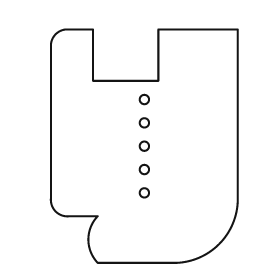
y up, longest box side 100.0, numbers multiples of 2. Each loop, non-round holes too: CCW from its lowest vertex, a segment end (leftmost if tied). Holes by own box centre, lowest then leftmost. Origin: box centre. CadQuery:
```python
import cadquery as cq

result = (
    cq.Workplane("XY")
    .moveTo(-20.0, -50.0)
    .lineTo(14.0, -50.0)
    .threePointArc((32.0, -42.0), (40.0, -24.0))
    .lineTo(40.0, 50.0)
    .lineTo(6.0, 50.0)
    .lineTo(6.0, 28.0)
    .lineTo(-22.0, 28.0)
    .lineTo(-22.0, 50.0)
    .lineTo(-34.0, 50.0)
    .threePointArc((-38.0, 48.0), (-40.0, 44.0))
    .lineTo(-40.0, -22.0)
    .threePointArc((-38.0, -28.0), (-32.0, -30.0))
    .lineTo(-20.0, -30.0)
    .threePointArc((-24.0, -40.0), (-20.0, -50.0))
    .close()
    .moveTo(0.0, -20.0)
    .circle(2.0)
    .moveTo(0.0, -10.0)
    .circle(2.0)
    .moveTo(0.0, 0.0)
    .circle(2.0)
    .moveTo(0.0, 10.0)
    .circle(2.0)
    .moveTo(0.0, 20.0)
    .circle(2.0)
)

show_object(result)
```